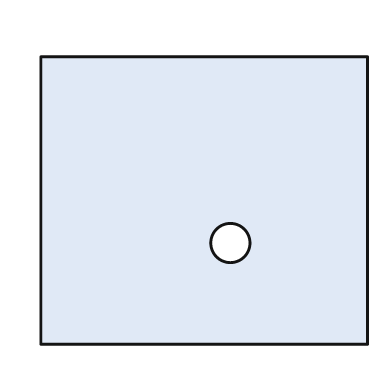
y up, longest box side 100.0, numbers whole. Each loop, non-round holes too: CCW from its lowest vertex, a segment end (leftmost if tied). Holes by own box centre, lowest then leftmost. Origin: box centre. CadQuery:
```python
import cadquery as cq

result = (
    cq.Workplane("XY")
    .moveTo(-50.0, -44.0)
    .lineTo(50.0, -44.0)
    .lineTo(50.0, 44.0)
    .lineTo(-50.0, 44.0)
    .close()
    .moveTo(8.0, -13.0)
    .circle(6.0)
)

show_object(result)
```